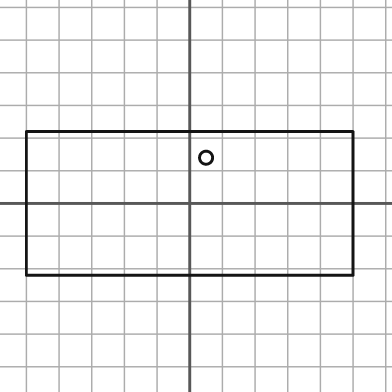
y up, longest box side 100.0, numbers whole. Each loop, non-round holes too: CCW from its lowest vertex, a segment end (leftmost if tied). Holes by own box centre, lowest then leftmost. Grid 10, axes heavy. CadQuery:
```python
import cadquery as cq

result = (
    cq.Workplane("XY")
    .moveTo(-50.0, -22.0)
    .lineTo(50.0, -22.0)
    .lineTo(50.0, 22.0)
    .lineTo(-50.0, 22.0)
    .close()
    .moveTo(5.0, 14.0)
    .circle(2.0)
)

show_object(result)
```